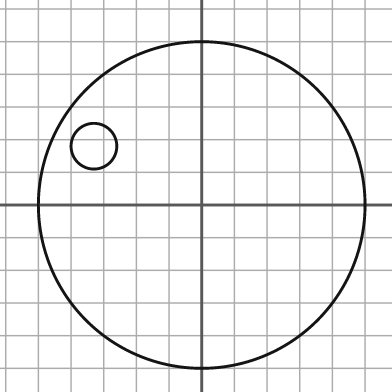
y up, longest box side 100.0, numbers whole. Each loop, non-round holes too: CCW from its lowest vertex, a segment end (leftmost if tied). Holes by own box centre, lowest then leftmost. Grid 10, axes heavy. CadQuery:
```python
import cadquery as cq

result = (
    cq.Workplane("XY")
    .moveTo(0.0, 0.0)
    .circle(50.0)
    .moveTo(-33.0, 18.0)
    .circle(7.0)
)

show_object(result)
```